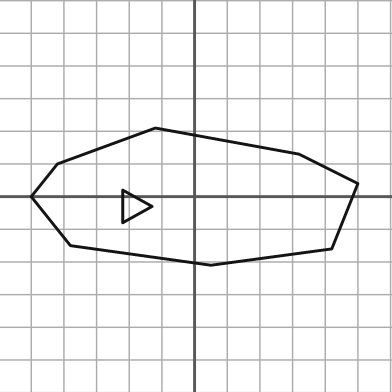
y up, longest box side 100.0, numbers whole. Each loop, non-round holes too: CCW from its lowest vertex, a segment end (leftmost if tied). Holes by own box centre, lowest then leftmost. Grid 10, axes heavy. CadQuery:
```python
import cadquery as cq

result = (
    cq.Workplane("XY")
    .moveTo(5.0, -21.0)
    .lineTo(42.0, -16.0)
    .lineTo(50.0, 4.0)
    .lineTo(32.0, 13.0)
    .lineTo(-12.0, 21.0)
    .lineTo(-42.0, 10.0)
    .lineTo(-50.0, 0.0)
    .lineTo(-38.0, -15.0)
    .close()
    .moveTo(-22.0, -8.0)
    .lineTo(-13.0, -3.0)
    .lineTo(-22.0, 2.0)
    .close()
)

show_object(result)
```